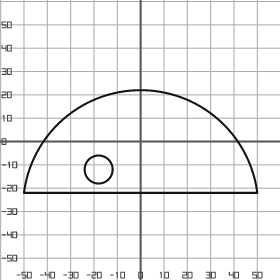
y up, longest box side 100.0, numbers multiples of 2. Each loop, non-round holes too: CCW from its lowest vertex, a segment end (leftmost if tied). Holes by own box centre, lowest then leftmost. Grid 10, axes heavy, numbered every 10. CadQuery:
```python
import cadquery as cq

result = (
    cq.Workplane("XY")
    .moveTo(-50.0, -22.0)
    .lineTo(50.0, -22.0)
    .threePointArc((0.0, 22.0), (-50.0, -22.0))
    .close()
    .moveTo(-18.0, -12.0)
    .circle(6.0)
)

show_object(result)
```